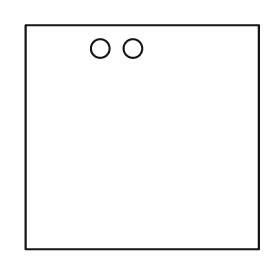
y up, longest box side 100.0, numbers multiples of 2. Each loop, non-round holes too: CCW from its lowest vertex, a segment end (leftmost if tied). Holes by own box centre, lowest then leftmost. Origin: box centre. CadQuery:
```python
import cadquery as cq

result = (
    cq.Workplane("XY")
    .moveTo(-50.0, -48.0)
    .lineTo(50.0, -48.0)
    .lineTo(50.0, 48.0)
    .lineTo(-50.0, 48.0)
    .close()
    .moveTo(-18.0, 38.0)
    .circle(4.0)
    .moveTo(-4.0, 38.0)
    .circle(4.0)
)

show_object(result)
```